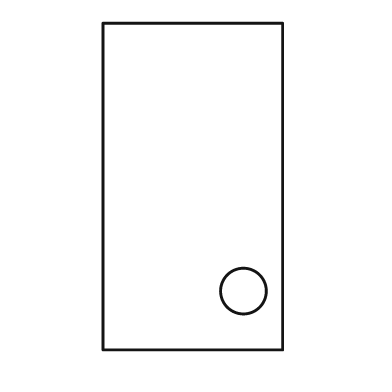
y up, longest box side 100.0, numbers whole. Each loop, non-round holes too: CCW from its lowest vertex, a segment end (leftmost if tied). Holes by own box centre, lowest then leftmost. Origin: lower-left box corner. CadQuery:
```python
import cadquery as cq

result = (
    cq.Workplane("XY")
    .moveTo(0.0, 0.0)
    .lineTo(55.0, 0.0)
    .lineTo(55.0, 100.0)
    .lineTo(0.0, 100.0)
    .close()
    .moveTo(43.0, 18.0)
    .circle(7.0)
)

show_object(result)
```